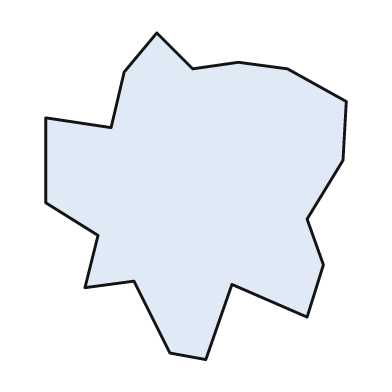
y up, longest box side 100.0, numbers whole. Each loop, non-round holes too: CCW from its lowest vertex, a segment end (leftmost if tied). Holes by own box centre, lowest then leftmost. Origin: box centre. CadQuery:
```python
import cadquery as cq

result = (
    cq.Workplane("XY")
    .moveTo(3.0, -50.0)
    .lineTo(11.0, -27.0)
    .lineTo(34.0, -37.0)
    .lineTo(39.0, -21.0)
    .lineTo(34.0, -7.0)
    .lineTo(45.0, 11.0)
    .lineTo(46.0, 29.0)
    .lineTo(28.0, 39.0)
    .lineTo(13.0, 41.0)
    .lineTo(-1.0, 39.0)
    .lineTo(-12.0, 50.0)
    .lineTo(-22.0, 38.0)
    .lineTo(-26.0, 21.0)
    .lineTo(-46.0, 24.0)
    .lineTo(-46.0, -2.0)
    .lineTo(-30.0, -12.0)
    .lineTo(-34.0, -28.0)
    .lineTo(-19.0, -26.0)
    .lineTo(-8.0, -48.0)
    .close()
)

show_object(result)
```